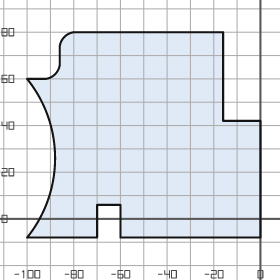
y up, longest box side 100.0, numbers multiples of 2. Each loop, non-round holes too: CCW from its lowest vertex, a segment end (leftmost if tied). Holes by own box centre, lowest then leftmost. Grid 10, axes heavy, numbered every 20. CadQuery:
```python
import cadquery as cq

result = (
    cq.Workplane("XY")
    .moveTo(-100.0, -8.0)
    .lineTo(-70.0, -8.0)
    .lineTo(-70.0, 6.0)
    .lineTo(-60.0, 6.0)
    .lineTo(-60.0, -8.0)
    .lineTo(0.0, -8.0)
    .lineTo(0.0, 42.0)
    .lineTo(-16.0, 42.0)
    .lineTo(-16.0, 80.0)
    .lineTo(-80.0, 80.0)
    .threePointArc((-84.0, 78.0), (-86.0, 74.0))
    .lineTo(-86.0, 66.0)
    .threePointArc((-88.0, 62.0), (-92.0, 60.0))
    .lineTo(-100.0, 60.0)
    .threePointArc((-88.0, 26.0), (-100.0, -8.0))
    .close()
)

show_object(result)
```